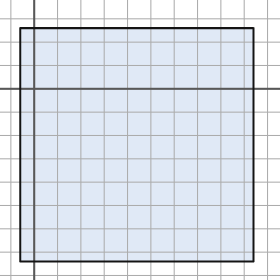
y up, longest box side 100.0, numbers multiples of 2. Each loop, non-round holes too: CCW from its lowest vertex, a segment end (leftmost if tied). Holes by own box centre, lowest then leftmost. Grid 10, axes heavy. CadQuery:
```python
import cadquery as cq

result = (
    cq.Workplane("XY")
    .moveTo(-6.0, -74.0)
    .lineTo(94.0, -74.0)
    .lineTo(94.0, 26.0)
    .lineTo(-6.0, 26.0)
    .close()
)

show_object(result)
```